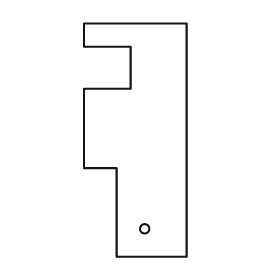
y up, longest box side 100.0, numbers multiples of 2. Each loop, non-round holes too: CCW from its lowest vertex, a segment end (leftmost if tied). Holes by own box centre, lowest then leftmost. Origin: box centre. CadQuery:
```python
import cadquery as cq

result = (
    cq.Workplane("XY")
    .moveTo(-8.0, -50.0)
    .lineTo(22.0, -50.0)
    .lineTo(22.0, 50.0)
    .lineTo(-22.0, 50.0)
    .lineTo(-22.0, 40.0)
    .lineTo(-2.0, 40.0)
    .lineTo(-2.0, 22.0)
    .lineTo(-22.0, 22.0)
    .lineTo(-22.0, -12.0)
    .lineTo(-8.0, -12.0)
    .close()
    .moveTo(4.0, -38.0)
    .circle(2.0)
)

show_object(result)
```